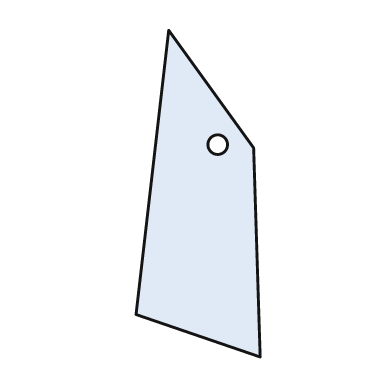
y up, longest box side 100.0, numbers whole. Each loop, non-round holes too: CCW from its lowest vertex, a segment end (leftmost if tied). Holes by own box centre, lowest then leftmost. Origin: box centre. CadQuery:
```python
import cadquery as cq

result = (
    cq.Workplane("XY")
    .moveTo(19.0, -50.0)
    .lineTo(17.0, 14.0)
    .lineTo(-9.0, 50.0)
    .lineTo(-19.0, -37.0)
    .close()
    .moveTo(6.0, 15.0)
    .circle(3.0)
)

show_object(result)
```